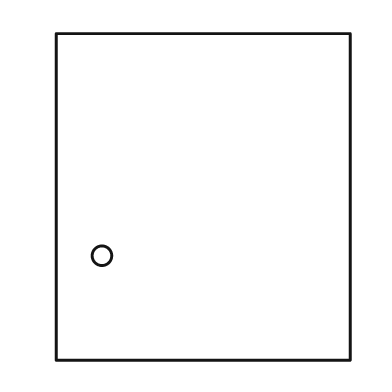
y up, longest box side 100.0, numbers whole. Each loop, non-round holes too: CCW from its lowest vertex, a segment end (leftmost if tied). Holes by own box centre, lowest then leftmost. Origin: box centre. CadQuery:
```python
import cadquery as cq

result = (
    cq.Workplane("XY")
    .moveTo(-45.0, -50.0)
    .lineTo(45.0, -50.0)
    .lineTo(45.0, 50.0)
    .lineTo(-45.0, 50.0)
    .close()
    .moveTo(-31.0, -18.0)
    .circle(3.0)
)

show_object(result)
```